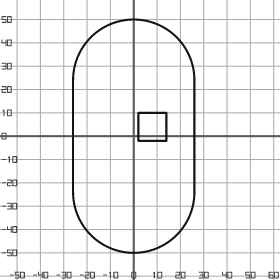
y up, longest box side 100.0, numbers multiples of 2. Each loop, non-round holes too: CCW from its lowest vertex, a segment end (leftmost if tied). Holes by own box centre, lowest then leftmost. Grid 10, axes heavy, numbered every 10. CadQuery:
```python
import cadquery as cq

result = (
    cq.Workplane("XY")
    .moveTo(-26.0, -24.0)
    .threePointArc((0.0, -50.0), (26.0, -24.0))
    .lineTo(26.0, 24.0)
    .threePointArc((0.0, 50.0), (-26.0, 24.0))
    .close()
    .moveTo(2.0, -2.0)
    .lineTo(14.0, -2.0)
    .lineTo(14.0, 10.0)
    .lineTo(2.0, 10.0)
    .close()
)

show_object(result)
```